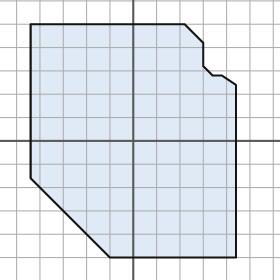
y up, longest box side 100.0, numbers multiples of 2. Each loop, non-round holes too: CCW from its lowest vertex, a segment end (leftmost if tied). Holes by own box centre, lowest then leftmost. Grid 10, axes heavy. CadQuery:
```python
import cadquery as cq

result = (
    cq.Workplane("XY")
    .moveTo(-10.0, -50.0)
    .lineTo(44.0, -50.0)
    .lineTo(44.0, 24.0)
    .lineTo(38.0, 28.0)
    .lineTo(34.0, 28.0)
    .lineTo(30.0, 32.0)
    .lineTo(30.0, 42.0)
    .lineTo(22.0, 50.0)
    .lineTo(-44.0, 50.0)
    .lineTo(-44.0, -16.0)
    .close()
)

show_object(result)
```